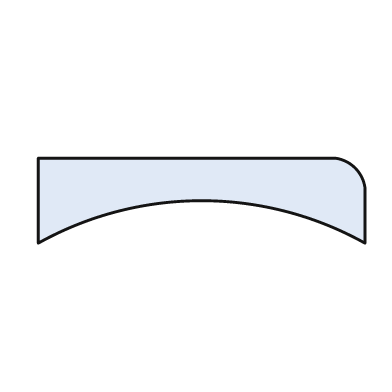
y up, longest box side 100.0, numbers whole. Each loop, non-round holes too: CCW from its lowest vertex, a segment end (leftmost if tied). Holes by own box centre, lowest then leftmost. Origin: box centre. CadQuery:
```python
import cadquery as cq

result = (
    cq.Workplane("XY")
    .moveTo(-50.0, -13.0)
    .threePointArc((0.0, 0.0), (50.0, -13.0))
    .lineTo(50.0, 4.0)
    .threePointArc((47.0, 10.0), (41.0, 13.0))
    .lineTo(-50.0, 13.0)
    .close()
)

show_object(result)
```